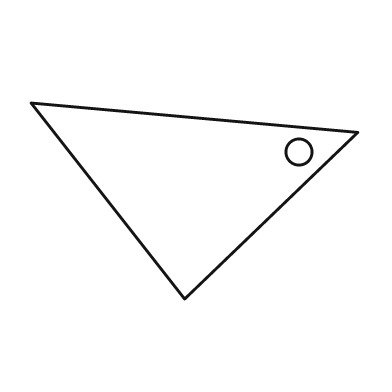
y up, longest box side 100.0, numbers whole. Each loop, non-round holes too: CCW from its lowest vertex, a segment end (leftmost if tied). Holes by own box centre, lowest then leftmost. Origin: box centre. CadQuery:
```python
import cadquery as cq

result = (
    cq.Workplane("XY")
    .moveTo(-3.0, -30.0)
    .lineTo(50.0, 21.0)
    .lineTo(-50.0, 30.0)
    .close()
    .moveTo(32.0, 15.0)
    .circle(4.0)
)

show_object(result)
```